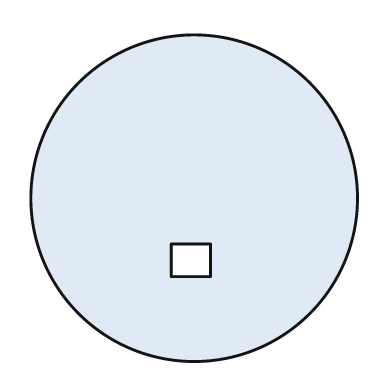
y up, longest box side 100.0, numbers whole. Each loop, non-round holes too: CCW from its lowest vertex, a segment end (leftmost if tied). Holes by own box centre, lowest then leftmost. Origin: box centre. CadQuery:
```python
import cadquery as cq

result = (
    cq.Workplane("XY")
    .moveTo(0.0, 0.0)
    .circle(50.0)
    .moveTo(-7.0, -24.0)
    .lineTo(5.0, -24.0)
    .lineTo(5.0, -14.0)
    .lineTo(-7.0, -14.0)
    .close()
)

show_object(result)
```